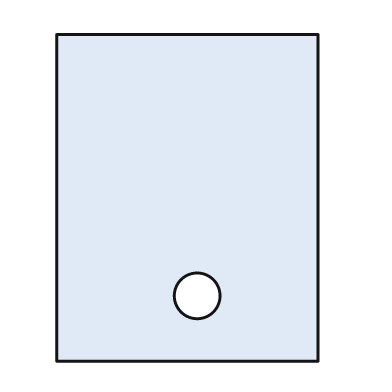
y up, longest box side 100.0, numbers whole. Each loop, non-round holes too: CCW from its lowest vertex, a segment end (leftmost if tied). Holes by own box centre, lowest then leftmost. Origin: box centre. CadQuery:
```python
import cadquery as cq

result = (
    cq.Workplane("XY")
    .moveTo(-40.0, -50.0)
    .lineTo(40.0, -50.0)
    .lineTo(40.0, 50.0)
    .lineTo(-40.0, 50.0)
    .close()
    .moveTo(3.0, -30.0)
    .circle(7.0)
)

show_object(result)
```